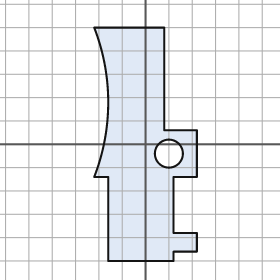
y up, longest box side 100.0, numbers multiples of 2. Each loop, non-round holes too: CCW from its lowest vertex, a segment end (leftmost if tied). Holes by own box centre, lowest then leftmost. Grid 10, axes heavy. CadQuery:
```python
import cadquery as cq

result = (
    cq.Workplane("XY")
    .moveTo(-16.0, -50.0)
    .lineTo(12.0, -50.0)
    .lineTo(12.0, -46.0)
    .lineTo(22.0, -46.0)
    .lineTo(22.0, -38.0)
    .lineTo(12.0, -38.0)
    .lineTo(12.0, -14.0)
    .lineTo(22.0, -14.0)
    .lineTo(22.0, 6.0)
    .lineTo(8.0, 6.0)
    .lineTo(8.0, 50.0)
    .lineTo(-22.0, 50.0)
    .threePointArc((-16.0, 18.0), (-22.0, -14.0))
    .lineTo(-16.0, -14.0)
    .close()
    .moveTo(10.0, -4.0)
    .circle(6.0)
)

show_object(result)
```